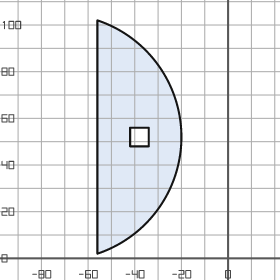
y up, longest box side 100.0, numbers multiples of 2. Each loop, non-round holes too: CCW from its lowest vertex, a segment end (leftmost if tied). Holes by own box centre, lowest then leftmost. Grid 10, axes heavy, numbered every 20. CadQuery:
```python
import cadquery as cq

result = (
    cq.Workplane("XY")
    .moveTo(-56.0, 2.0)
    .threePointArc((-20.0, 52.0), (-56.0, 102.0))
    .close()
    .moveTo(-42.0, 48.0)
    .lineTo(-34.0, 48.0)
    .lineTo(-34.0, 56.0)
    .lineTo(-42.0, 56.0)
    .close()
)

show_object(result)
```